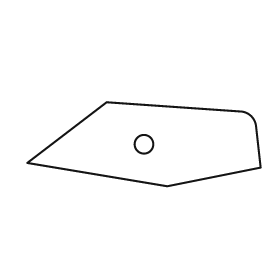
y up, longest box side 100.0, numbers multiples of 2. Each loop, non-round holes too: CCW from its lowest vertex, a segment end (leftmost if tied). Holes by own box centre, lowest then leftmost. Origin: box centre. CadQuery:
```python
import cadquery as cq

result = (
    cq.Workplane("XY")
    .moveTo(10.0, -18.0)
    .lineTo(50.0, -10.0)
    .lineTo(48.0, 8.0)
    .threePointArc((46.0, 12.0), (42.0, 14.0))
    .lineTo(-16.0, 18.0)
    .lineTo(-50.0, -8.0)
    .close()
    .moveTo(0.0, 0.0)
    .circle(4.0)
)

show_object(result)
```